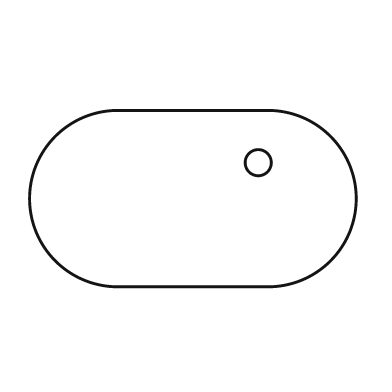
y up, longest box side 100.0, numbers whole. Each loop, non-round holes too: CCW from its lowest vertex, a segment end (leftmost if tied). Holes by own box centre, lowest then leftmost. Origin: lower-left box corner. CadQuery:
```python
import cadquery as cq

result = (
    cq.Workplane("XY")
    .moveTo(27.0, 0.0)
    .lineTo(73.0, 0.0)
    .threePointArc((100.0, 27.0), (73.0, 54.0))
    .lineTo(27.0, 54.0)
    .threePointArc((0.0, 27.0), (27.0, 0.0))
    .close()
    .moveTo(70.0, 38.0)
    .circle(4.0)
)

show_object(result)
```